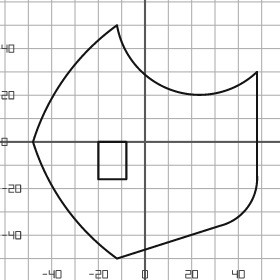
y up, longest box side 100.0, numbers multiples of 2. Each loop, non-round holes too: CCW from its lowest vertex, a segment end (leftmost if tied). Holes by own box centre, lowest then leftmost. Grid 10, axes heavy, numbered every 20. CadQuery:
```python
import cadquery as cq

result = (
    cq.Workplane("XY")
    .moveTo(-12.0, -50.0)
    .lineTo(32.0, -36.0)
    .threePointArc((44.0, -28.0), (48.0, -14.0))
    .lineTo(48.0, 30.0)
    .threePointArc((12.0, 22.0), (-12.0, 50.0))
    .threePointArc((-34.0, 28.0), (-48.0, 0.0))
    .threePointArc((-34.0, -28.0), (-12.0, -50.0))
    .close()
    .moveTo(-20.0, -16.0)
    .lineTo(-8.0, -16.0)
    .lineTo(-8.0, 0.0)
    .lineTo(-20.0, 0.0)
    .close()
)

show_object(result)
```